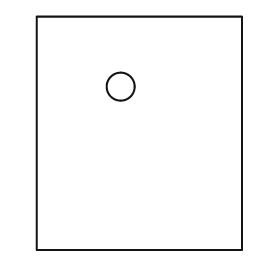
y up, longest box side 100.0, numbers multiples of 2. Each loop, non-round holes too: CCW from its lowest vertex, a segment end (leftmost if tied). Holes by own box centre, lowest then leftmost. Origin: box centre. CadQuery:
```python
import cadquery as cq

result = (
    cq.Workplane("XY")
    .moveTo(-44.0, -50.0)
    .lineTo(44.0, -50.0)
    .lineTo(44.0, 50.0)
    .lineTo(-44.0, 50.0)
    .close()
    .moveTo(-8.0, 20.0)
    .circle(6.0)
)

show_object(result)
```